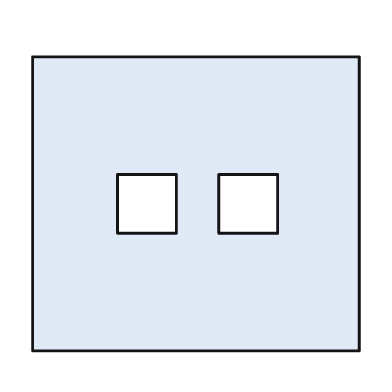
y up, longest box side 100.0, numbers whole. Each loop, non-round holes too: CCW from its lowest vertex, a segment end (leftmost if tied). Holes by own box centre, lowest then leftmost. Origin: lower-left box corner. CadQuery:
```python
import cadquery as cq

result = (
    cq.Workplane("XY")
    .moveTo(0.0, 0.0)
    .lineTo(100.0, 0.0)
    .lineTo(100.0, 90.0)
    .lineTo(0.0, 90.0)
    .close()
    .moveTo(26.0, 36.0)
    .lineTo(44.0, 36.0)
    .lineTo(44.0, 54.0)
    .lineTo(26.0, 54.0)
    .close()
    .moveTo(57.0, 36.0)
    .lineTo(75.0, 36.0)
    .lineTo(75.0, 54.0)
    .lineTo(57.0, 54.0)
    .close()
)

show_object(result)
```